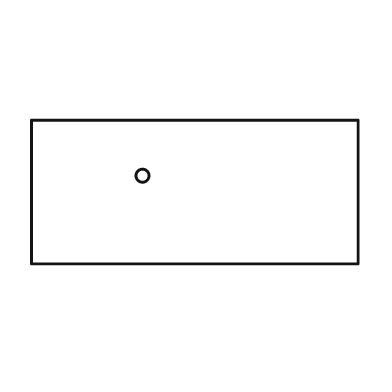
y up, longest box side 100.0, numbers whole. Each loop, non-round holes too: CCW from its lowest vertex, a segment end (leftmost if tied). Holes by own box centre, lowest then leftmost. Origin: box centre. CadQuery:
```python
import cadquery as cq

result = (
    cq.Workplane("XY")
    .moveTo(-50.0, -22.0)
    .lineTo(50.0, -22.0)
    .lineTo(50.0, 22.0)
    .lineTo(-50.0, 22.0)
    .close()
    .moveTo(-16.0, 5.0)
    .circle(2.0)
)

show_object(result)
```